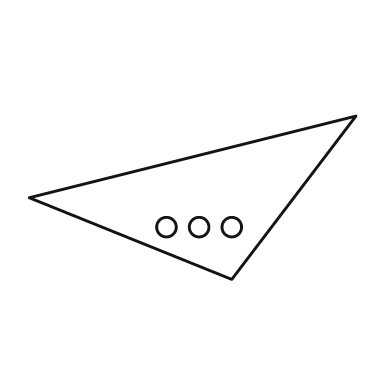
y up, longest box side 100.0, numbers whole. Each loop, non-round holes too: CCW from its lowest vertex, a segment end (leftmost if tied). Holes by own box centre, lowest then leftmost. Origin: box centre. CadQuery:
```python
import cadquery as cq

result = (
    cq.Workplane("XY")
    .moveTo(12.0, -25.0)
    .lineTo(50.0, 25.0)
    .lineTo(-50.0, 0.0)
    .close()
    .moveTo(-8.0, -9.0)
    .circle(3.0)
    .moveTo(2.0, -9.0)
    .circle(3.0)
    .moveTo(12.0, -9.0)
    .circle(3.0)
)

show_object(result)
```